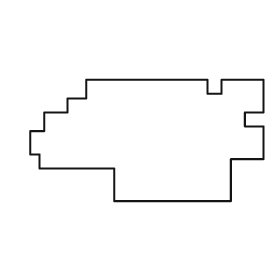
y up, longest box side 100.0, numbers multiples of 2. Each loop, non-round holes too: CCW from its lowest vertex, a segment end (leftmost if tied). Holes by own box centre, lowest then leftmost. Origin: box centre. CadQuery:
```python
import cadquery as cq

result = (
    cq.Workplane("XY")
    .moveTo(-14.0, -26.0)
    .lineTo(36.0, -26.0)
    .lineTo(36.0, -8.0)
    .lineTo(50.0, -8.0)
    .lineTo(50.0, 6.0)
    .lineTo(42.0, 6.0)
    .lineTo(42.0, 12.0)
    .lineTo(50.0, 12.0)
    .lineTo(50.0, 26.0)
    .lineTo(32.0, 26.0)
    .lineTo(32.0, 20.0)
    .lineTo(26.0, 20.0)
    .lineTo(26.0, 26.0)
    .lineTo(-26.0, 26.0)
    .lineTo(-26.0, 18.0)
    .lineTo(-34.0, 18.0)
    .lineTo(-34.0, 12.0)
    .lineTo(-44.0, 12.0)
    .lineTo(-44.0, 4.0)
    .lineTo(-50.0, 4.0)
    .lineTo(-50.0, -6.0)
    .lineTo(-46.0, -6.0)
    .lineTo(-46.0, -12.0)
    .lineTo(-14.0, -12.0)
    .close()
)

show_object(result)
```